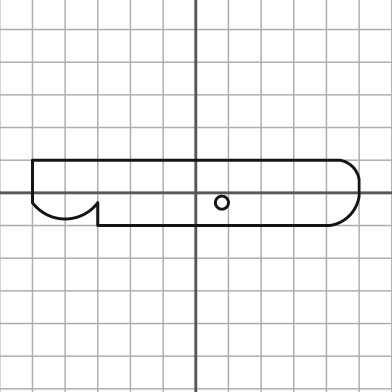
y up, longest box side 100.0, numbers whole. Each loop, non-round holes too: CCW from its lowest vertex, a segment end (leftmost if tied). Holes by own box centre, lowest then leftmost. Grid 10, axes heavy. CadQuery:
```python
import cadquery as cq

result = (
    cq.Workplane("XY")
    .moveTo(-30.0, -10.0)
    .lineTo(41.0, -10.0)
    .threePointArc((47.0, -7.0), (50.0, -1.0))
    .lineTo(50.0, 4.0)
    .threePointArc((48.0, 8.0), (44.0, 10.0))
    .lineTo(-50.0, 10.0)
    .lineTo(-50.0, -3.0)
    .threePointArc((-40.0, -8.0), (-30.0, -3.0))
    .close()
    .moveTo(8.0, -3.0)
    .circle(2.0)
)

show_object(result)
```